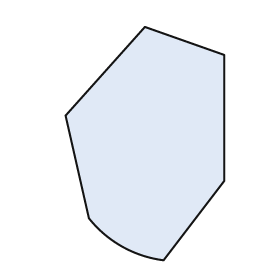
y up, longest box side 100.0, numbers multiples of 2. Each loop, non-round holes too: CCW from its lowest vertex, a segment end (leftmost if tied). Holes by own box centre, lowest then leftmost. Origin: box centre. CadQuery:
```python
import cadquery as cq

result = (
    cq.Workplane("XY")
    .moveTo(8.0, -50.0)
    .lineTo(34.0, -16.0)
    .lineTo(34.0, 38.0)
    .lineTo(0.0, 50.0)
    .lineTo(-34.0, 12.0)
    .lineTo(-24.0, -32.0)
    .threePointArc((-10.0, -44.0), (8.0, -50.0))
    .close()
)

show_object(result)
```